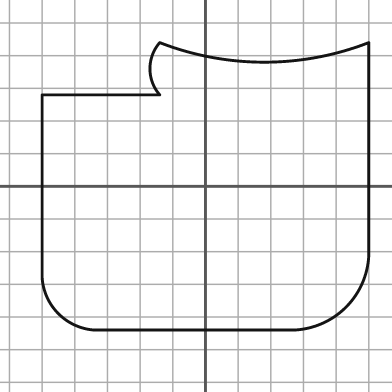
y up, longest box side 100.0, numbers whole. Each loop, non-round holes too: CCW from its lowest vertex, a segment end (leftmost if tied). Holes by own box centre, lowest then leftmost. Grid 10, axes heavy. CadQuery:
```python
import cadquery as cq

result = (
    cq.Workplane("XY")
    .moveTo(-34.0, -44.0)
    .lineTo(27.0, -44.0)
    .threePointArc((43.0, -37.0), (50.0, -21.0))
    .lineTo(50.0, 44.0)
    .threePointArc((18.0, 38.0), (-14.0, 44.0))
    .threePointArc((-17.0, 36.0), (-14.0, 28.0))
    .lineTo(-50.0, 28.0)
    .lineTo(-50.0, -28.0)
    .threePointArc((-45.0, -39.0), (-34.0, -44.0))
    .close()
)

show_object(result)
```